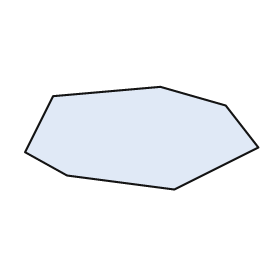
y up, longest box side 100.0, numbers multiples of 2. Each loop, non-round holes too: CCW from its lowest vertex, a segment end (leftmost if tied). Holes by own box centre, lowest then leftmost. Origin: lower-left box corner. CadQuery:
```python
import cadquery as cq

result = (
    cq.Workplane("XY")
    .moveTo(64.0, 0.0)
    .lineTo(100.0, 18.0)
    .lineTo(86.0, 36.0)
    .lineTo(58.0, 44.0)
    .lineTo(12.0, 40.0)
    .lineTo(0.0, 16.0)
    .lineTo(18.0, 6.0)
    .close()
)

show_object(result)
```